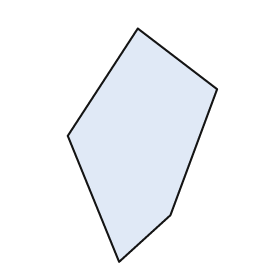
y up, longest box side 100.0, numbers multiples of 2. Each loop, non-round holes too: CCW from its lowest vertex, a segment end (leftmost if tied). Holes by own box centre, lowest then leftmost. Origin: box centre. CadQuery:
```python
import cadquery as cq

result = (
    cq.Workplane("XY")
    .moveTo(-10.0, -50.0)
    .lineTo(12.0, -30.0)
    .lineTo(32.0, 24.0)
    .lineTo(-2.0, 50.0)
    .lineTo(-32.0, 4.0)
    .close()
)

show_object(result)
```